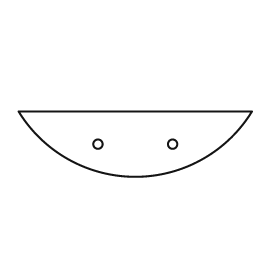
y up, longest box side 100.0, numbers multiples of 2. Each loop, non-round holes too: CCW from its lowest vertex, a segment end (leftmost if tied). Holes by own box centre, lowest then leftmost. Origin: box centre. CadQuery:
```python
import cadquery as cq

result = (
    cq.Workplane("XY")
    .moveTo(-50.0, 14.0)
    .threePointArc((0.0, -14.0), (50.0, 14.0))
    .close()
    .moveTo(-16.0, 0.0)
    .circle(2.0)
    .moveTo(16.0, 0.0)
    .circle(2.0)
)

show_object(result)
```